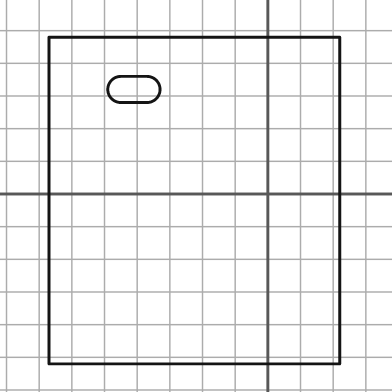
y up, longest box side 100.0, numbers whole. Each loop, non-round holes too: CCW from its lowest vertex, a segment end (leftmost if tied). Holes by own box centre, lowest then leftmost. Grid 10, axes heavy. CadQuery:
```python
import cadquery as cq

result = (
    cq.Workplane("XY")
    .moveTo(-67.0, -52.0)
    .lineTo(22.0, -52.0)
    .lineTo(22.0, 48.0)
    .lineTo(-67.0, 48.0)
    .close()
    .moveTo(-45.0, 28.0)
    .lineTo(-37.0, 28.0)
    .threePointArc((-33.0, 32.0), (-37.0, 36.0))
    .lineTo(-45.0, 36.0)
    .threePointArc((-49.0, 32.0), (-45.0, 28.0))
    .close()
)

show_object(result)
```